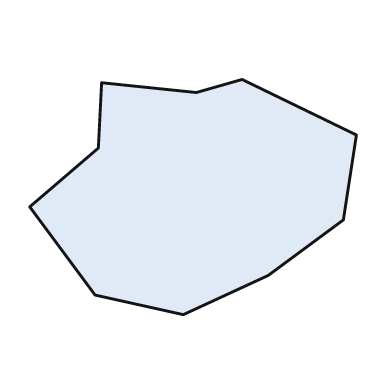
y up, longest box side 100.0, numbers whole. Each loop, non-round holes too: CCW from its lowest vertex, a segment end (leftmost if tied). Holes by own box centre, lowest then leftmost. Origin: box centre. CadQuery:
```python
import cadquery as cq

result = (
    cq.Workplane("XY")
    .moveTo(-3.0, -36.0)
    .lineTo(23.0, -24.0)
    .lineTo(46.0, -7.0)
    .lineTo(50.0, 19.0)
    .lineTo(15.0, 36.0)
    .lineTo(1.0, 32.0)
    .lineTo(-28.0, 35.0)
    .lineTo(-29.0, 15.0)
    .lineTo(-50.0, -3.0)
    .lineTo(-30.0, -30.0)
    .close()
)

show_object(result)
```